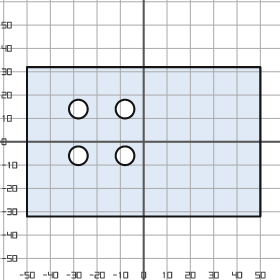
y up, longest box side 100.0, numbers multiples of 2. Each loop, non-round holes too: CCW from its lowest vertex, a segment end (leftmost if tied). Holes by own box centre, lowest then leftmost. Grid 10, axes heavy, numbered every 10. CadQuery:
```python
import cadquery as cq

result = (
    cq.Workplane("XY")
    .moveTo(-50.0, -32.0)
    .lineTo(50.0, -32.0)
    .lineTo(50.0, 32.0)
    .lineTo(-50.0, 32.0)
    .close()
    .moveTo(-28.0, -6.0)
    .circle(4.0)
    .moveTo(-8.0, -6.0)
    .circle(4.0)
    .moveTo(-28.0, 14.0)
    .circle(4.0)
    .moveTo(-8.0, 14.0)
    .circle(4.0)
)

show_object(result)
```